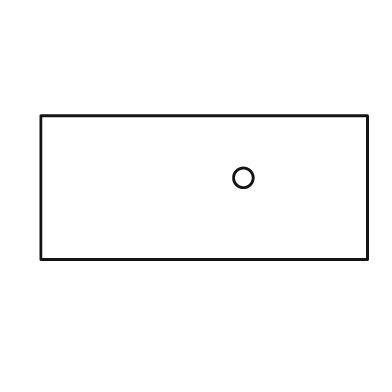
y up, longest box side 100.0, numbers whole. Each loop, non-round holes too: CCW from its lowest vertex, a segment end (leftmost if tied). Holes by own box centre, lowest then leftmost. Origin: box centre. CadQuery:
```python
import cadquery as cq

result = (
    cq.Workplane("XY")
    .moveTo(-50.0, -22.0)
    .lineTo(50.0, -22.0)
    .lineTo(50.0, 22.0)
    .lineTo(-50.0, 22.0)
    .close()
    .moveTo(12.0, 3.0)
    .circle(3.0)
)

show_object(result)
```